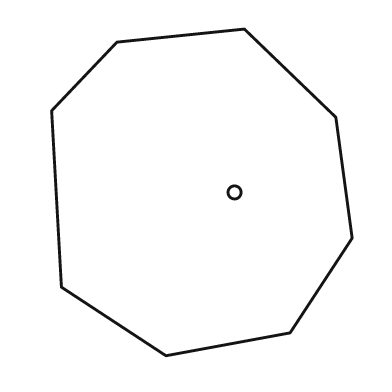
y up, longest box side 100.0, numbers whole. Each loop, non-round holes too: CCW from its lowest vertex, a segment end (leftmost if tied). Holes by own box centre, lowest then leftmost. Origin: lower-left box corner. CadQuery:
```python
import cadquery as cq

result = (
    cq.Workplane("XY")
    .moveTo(35.0, 0.0)
    .lineTo(73.0, 7.0)
    .lineTo(92.0, 36.0)
    .lineTo(87.0, 73.0)
    .lineTo(59.0, 100.0)
    .lineTo(20.0, 96.0)
    .lineTo(0.0, 75.0)
    .lineTo(3.0, 21.0)
    .close()
    .moveTo(56.0, 50.0)
    .circle(2.0)
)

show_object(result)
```